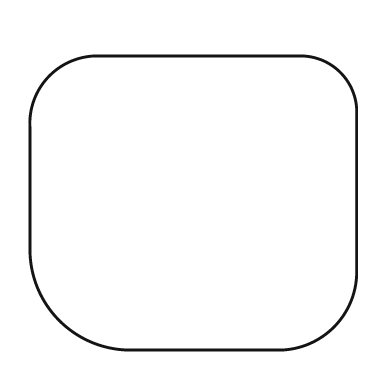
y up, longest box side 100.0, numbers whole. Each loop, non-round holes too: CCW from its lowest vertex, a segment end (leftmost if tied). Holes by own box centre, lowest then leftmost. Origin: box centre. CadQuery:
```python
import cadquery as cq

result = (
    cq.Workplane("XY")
    .moveTo(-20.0, -45.0)
    .lineTo(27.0, -45.0)
    .threePointArc((43.0, -38.0), (50.0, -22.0))
    .lineTo(50.0, 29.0)
    .threePointArc((45.0, 40.0), (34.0, 45.0))
    .lineTo(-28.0, 45.0)
    .threePointArc((-44.0, 39.0), (-50.0, 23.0))
    .lineTo(-50.0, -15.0)
    .threePointArc((-41.0, -36.0), (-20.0, -45.0))
    .close()
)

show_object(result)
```